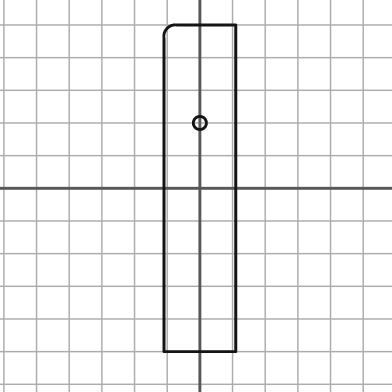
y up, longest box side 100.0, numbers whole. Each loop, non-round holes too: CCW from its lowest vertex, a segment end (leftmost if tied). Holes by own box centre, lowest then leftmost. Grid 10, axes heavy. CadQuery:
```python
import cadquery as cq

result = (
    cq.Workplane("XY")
    .moveTo(-11.0, -50.0)
    .lineTo(11.0, -50.0)
    .lineTo(11.0, 50.0)
    .lineTo(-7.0, 50.0)
    .threePointArc((-10.0, 49.0), (-11.0, 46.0))
    .close()
    .moveTo(0.0, 20.0)
    .circle(2.0)
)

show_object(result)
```